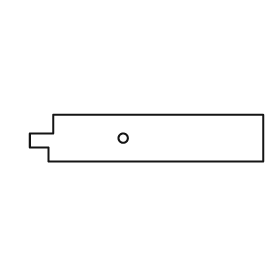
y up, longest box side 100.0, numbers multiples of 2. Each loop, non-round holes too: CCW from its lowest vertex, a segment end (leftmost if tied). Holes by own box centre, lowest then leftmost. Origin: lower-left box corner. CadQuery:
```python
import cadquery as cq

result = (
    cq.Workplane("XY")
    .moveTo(8.0, 0.0)
    .lineTo(100.0, 0.0)
    .lineTo(100.0, 20.0)
    .lineTo(10.0, 20.0)
    .lineTo(10.0, 12.0)
    .lineTo(0.0, 12.0)
    .lineTo(0.0, 6.0)
    .lineTo(8.0, 6.0)
    .close()
    .moveTo(40.0, 10.0)
    .circle(2.0)
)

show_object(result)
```